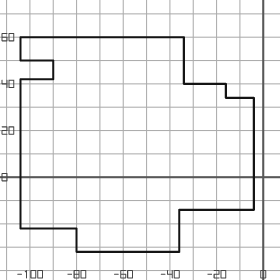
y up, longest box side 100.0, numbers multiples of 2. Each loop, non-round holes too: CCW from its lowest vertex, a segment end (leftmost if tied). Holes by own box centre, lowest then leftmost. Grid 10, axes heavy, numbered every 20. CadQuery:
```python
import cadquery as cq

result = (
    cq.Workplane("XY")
    .moveTo(-80.0, -32.0)
    .lineTo(-36.0, -32.0)
    .lineTo(-36.0, -14.0)
    .lineTo(-4.0, -14.0)
    .lineTo(-4.0, 34.0)
    .lineTo(-16.0, 34.0)
    .lineTo(-16.0, 40.0)
    .lineTo(-34.0, 40.0)
    .lineTo(-34.0, 60.0)
    .lineTo(-104.0, 60.0)
    .lineTo(-104.0, 50.0)
    .lineTo(-90.0, 50.0)
    .lineTo(-90.0, 42.0)
    .lineTo(-104.0, 42.0)
    .lineTo(-104.0, -22.0)
    .lineTo(-80.0, -22.0)
    .close()
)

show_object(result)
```